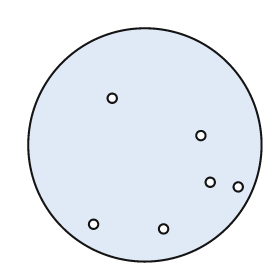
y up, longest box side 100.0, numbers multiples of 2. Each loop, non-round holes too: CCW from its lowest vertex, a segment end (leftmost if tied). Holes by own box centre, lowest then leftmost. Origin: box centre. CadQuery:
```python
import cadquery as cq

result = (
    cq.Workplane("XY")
    .moveTo(0.0, 0.0)
    .circle(50.0)
    .moveTo(8.0, -36.0)
    .circle(2.0)
    .moveTo(-22.0, -34.0)
    .circle(2.0)
    .moveTo(40.0, -18.0)
    .circle(2.0)
    .moveTo(28.0, -16.0)
    .circle(2.0)
    .moveTo(24.0, 4.0)
    .circle(2.0)
    .moveTo(-14.0, 20.0)
    .circle(2.0)
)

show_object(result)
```